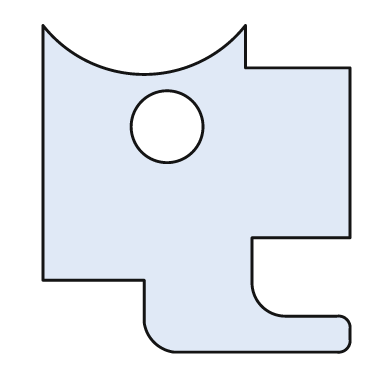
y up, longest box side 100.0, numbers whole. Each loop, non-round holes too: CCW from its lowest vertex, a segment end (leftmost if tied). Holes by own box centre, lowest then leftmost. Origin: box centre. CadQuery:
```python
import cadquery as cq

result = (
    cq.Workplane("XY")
    .moveTo(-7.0, -50.0)
    .lineTo(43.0, -50.0)
    .threePointArc((46.0, -49.0), (47.0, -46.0))
    .lineTo(47.0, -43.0)
    .threePointArc((46.0, -40.0), (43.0, -39.0))
    .lineTo(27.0, -39.0)
    .threePointArc((20.0, -36.0), (17.0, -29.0))
    .lineTo(17.0, -15.0)
    .lineTo(47.0, -15.0)
    .lineTo(47.0, 37.0)
    .lineTo(15.0, 37.0)
    .lineTo(15.0, 50.0)
    .threePointArc((-16.0, 35.0), (-47.0, 50.0))
    .lineTo(-47.0, -28.0)
    .lineTo(-16.0, -28.0)
    .lineTo(-16.0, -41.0)
    .threePointArc((-13.0, -47.0), (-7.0, -50.0))
    .close()
    .moveTo(-9.0, 19.0)
    .circle(11.0)
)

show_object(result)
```